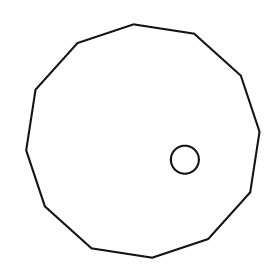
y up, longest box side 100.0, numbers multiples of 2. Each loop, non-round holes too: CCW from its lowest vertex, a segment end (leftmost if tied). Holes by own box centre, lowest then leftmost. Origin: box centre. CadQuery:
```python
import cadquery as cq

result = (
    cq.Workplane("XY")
    .moveTo(4.0, -50.0)
    .lineTo(28.0, -42.0)
    .lineTo(46.0, -22.0)
    .lineTo(50.0, 4.0)
    .lineTo(42.0, 28.0)
    .lineTo(22.0, 46.0)
    .lineTo(-4.0, 50.0)
    .lineTo(-28.0, 42.0)
    .lineTo(-46.0, 22.0)
    .lineTo(-50.0, -4.0)
    .lineTo(-42.0, -28.0)
    .lineTo(-22.0, -46.0)
    .close()
    .moveTo(18.0, -8.0)
    .circle(6.0)
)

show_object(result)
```